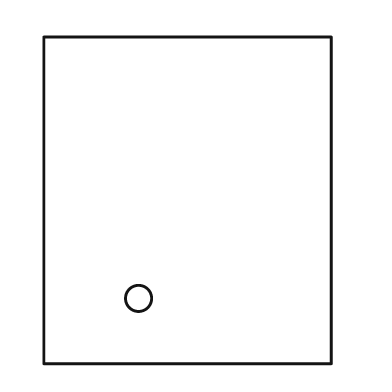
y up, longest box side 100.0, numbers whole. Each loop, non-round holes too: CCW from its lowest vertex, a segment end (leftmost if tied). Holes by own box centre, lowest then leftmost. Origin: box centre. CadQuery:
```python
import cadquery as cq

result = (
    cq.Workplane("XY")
    .moveTo(-44.0, -50.0)
    .lineTo(44.0, -50.0)
    .lineTo(44.0, 50.0)
    .lineTo(-44.0, 50.0)
    .close()
    .moveTo(-15.0, -30.0)
    .circle(4.0)
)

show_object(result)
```